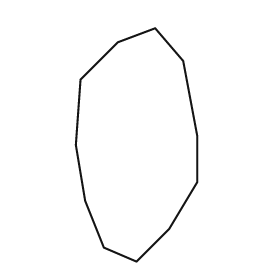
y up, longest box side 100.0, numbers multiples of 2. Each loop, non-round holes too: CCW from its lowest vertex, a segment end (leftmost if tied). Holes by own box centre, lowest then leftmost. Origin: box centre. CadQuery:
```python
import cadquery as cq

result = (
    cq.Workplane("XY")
    .moveTo(0.0, -50.0)
    .lineTo(14.0, -36.0)
    .lineTo(26.0, -16.0)
    .lineTo(26.0, 4.0)
    .lineTo(20.0, 36.0)
    .lineTo(8.0, 50.0)
    .lineTo(-8.0, 44.0)
    .lineTo(-24.0, 28.0)
    .lineTo(-26.0, 0.0)
    .lineTo(-22.0, -24.0)
    .lineTo(-14.0, -44.0)
    .close()
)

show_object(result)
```